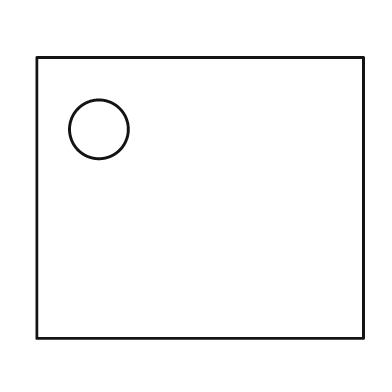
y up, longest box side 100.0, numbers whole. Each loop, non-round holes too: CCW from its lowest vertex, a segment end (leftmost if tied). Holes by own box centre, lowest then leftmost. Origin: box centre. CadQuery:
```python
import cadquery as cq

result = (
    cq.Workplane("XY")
    .moveTo(-50.0, -43.0)
    .lineTo(50.0, -43.0)
    .lineTo(50.0, 43.0)
    .lineTo(-50.0, 43.0)
    .close()
    .moveTo(-31.0, 21.0)
    .circle(9.0)
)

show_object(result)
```